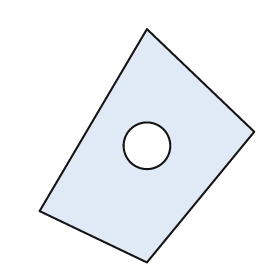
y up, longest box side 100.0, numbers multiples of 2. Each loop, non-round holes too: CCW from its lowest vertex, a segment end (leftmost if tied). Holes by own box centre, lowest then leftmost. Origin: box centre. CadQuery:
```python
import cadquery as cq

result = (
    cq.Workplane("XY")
    .moveTo(0.0, -50.0)
    .lineTo(46.0, 6.0)
    .lineTo(0.0, 50.0)
    .lineTo(-46.0, -28.0)
    .close()
    .moveTo(0.0, 0.0)
    .circle(10.0)
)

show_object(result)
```